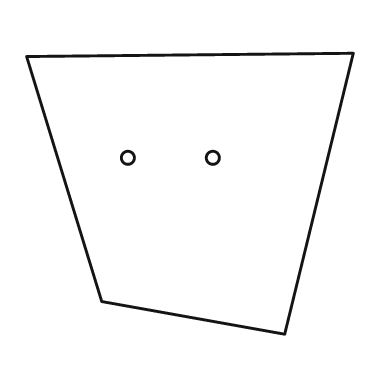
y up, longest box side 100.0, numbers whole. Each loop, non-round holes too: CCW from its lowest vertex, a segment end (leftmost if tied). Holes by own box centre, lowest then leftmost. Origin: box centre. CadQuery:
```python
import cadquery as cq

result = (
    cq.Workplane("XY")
    .moveTo(29.0, -43.0)
    .lineTo(50.0, 43.0)
    .lineTo(-50.0, 42.0)
    .lineTo(-27.0, -33.0)
    .close()
    .moveTo(-19.0, 11.0)
    .circle(2.0)
    .moveTo(7.0, 11.0)
    .circle(2.0)
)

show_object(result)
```